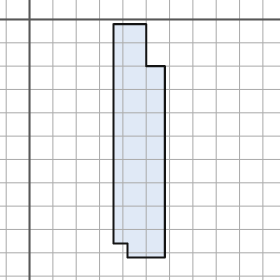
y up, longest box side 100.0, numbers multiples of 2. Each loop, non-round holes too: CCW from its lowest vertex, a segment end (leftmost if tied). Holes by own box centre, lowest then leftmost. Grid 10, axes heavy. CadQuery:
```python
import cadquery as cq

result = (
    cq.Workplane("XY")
    .moveTo(42.0, -102.0)
    .lineTo(58.0, -102.0)
    .lineTo(58.0, -20.0)
    .lineTo(50.0, -20.0)
    .lineTo(50.0, -2.0)
    .lineTo(36.0, -2.0)
    .lineTo(36.0, -96.0)
    .lineTo(42.0, -96.0)
    .close()
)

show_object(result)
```